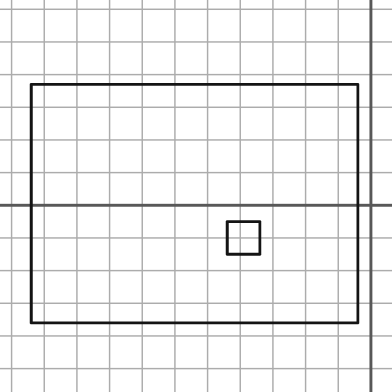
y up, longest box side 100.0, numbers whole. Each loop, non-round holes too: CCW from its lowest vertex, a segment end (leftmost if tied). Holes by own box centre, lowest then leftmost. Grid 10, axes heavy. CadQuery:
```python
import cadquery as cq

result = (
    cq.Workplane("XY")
    .moveTo(-104.0, -36.0)
    .lineTo(-4.0, -36.0)
    .lineTo(-4.0, 37.0)
    .lineTo(-104.0, 37.0)
    .close()
    .moveTo(-44.0, -15.0)
    .lineTo(-34.0, -15.0)
    .lineTo(-34.0, -5.0)
    .lineTo(-44.0, -5.0)
    .close()
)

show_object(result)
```